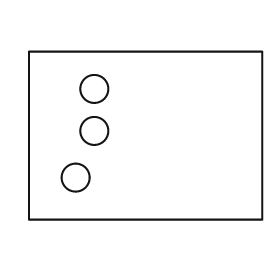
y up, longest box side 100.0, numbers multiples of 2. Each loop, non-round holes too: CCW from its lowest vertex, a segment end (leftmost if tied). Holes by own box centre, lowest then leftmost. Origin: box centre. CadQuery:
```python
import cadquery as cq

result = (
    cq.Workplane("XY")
    .moveTo(-50.0, -36.0)
    .lineTo(50.0, -36.0)
    .lineTo(50.0, 36.0)
    .lineTo(-50.0, 36.0)
    .close()
    .moveTo(-30.0, -18.0)
    .circle(6.0)
    .moveTo(-22.0, 2.0)
    .circle(6.0)
    .moveTo(-22.0, 20.0)
    .circle(6.0)
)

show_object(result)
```